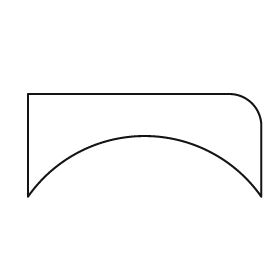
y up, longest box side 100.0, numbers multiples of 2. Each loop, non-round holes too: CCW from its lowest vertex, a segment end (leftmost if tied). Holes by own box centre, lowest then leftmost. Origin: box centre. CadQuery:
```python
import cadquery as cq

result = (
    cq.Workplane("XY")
    .moveTo(-50.0, -22.0)
    .threePointArc((0.0, 4.0), (50.0, -22.0))
    .lineTo(50.0, 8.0)
    .threePointArc((46.0, 18.0), (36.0, 22.0))
    .lineTo(-50.0, 22.0)
    .close()
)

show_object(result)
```